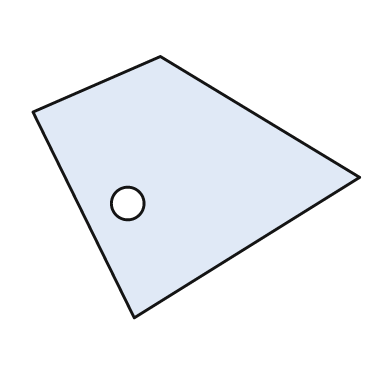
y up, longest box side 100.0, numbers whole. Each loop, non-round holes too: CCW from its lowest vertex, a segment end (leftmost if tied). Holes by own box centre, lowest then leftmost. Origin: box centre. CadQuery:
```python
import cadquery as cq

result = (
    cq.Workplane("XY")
    .moveTo(-19.0, -40.0)
    .lineTo(50.0, 3.0)
    .lineTo(-11.0, 40.0)
    .lineTo(-50.0, 23.0)
    .close()
    .moveTo(-21.0, -5.0)
    .circle(5.0)
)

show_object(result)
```